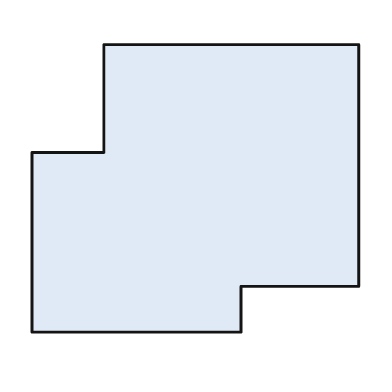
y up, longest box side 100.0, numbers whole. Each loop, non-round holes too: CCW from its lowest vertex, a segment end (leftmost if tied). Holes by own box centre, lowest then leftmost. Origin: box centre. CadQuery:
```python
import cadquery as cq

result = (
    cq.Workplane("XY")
    .moveTo(-50.0, -44.0)
    .lineTo(14.0, -44.0)
    .lineTo(14.0, -30.0)
    .lineTo(50.0, -30.0)
    .lineTo(50.0, 44.0)
    .lineTo(-28.0, 44.0)
    .lineTo(-28.0, 11.0)
    .lineTo(-50.0, 11.0)
    .close()
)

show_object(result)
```